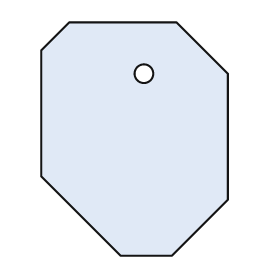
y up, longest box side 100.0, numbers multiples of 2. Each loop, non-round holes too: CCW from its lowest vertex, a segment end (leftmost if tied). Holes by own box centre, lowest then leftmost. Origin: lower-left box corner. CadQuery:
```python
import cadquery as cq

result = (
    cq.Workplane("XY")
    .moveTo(34.0, 0.0)
    .lineTo(56.0, 0.0)
    .lineTo(80.0, 24.0)
    .lineTo(80.0, 78.0)
    .lineTo(58.0, 100.0)
    .lineTo(12.0, 100.0)
    .lineTo(0.0, 88.0)
    .lineTo(0.0, 34.0)
    .close()
    .moveTo(44.0, 78.0)
    .circle(4.0)
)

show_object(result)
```